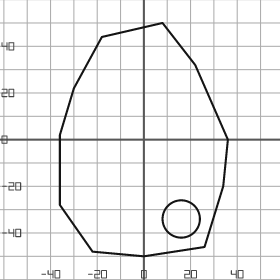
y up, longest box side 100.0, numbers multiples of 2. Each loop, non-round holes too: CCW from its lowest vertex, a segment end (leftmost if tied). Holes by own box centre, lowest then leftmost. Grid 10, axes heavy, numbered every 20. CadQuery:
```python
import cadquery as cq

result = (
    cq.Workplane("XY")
    .moveTo(0.0, -50.0)
    .lineTo(26.0, -46.0)
    .lineTo(34.0, -20.0)
    .lineTo(36.0, 0.0)
    .lineTo(22.0, 32.0)
    .lineTo(8.0, 50.0)
    .lineTo(-18.0, 44.0)
    .lineTo(-30.0, 22.0)
    .lineTo(-36.0, 2.0)
    .lineTo(-36.0, -28.0)
    .lineTo(-22.0, -48.0)
    .close()
    .moveTo(16.0, -34.0)
    .circle(8.0)
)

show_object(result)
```